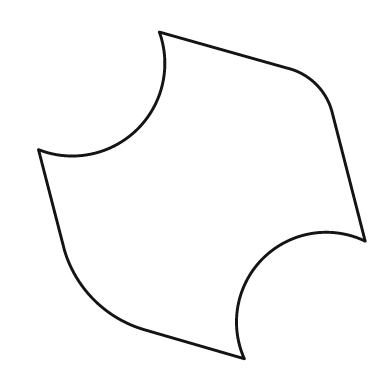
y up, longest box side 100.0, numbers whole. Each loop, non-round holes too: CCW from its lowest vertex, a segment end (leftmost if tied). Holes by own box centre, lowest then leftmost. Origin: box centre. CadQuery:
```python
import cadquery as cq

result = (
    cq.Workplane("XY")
    .moveTo(13.0, -50.0)
    .threePointArc((19.0, -19.0), (50.0, -14.0))
    .lineTo(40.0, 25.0)
    .threePointArc((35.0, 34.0), (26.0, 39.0))
    .lineTo(-13.0, 50.0)
    .threePointArc((-20.0, 20.0), (-50.0, 14.0))
    .lineTo(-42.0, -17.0)
    .threePointArc((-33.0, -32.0), (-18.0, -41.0))
    .close()
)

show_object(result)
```